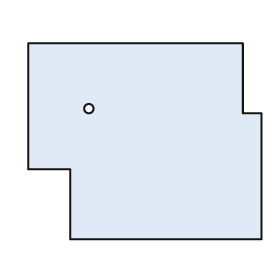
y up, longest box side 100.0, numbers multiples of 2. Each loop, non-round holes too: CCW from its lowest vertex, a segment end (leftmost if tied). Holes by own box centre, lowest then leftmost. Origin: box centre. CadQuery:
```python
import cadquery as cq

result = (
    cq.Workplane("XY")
    .moveTo(-32.0, -42.0)
    .lineTo(50.0, -42.0)
    .lineTo(50.0, 12.0)
    .lineTo(42.0, 12.0)
    .lineTo(42.0, 42.0)
    .lineTo(-50.0, 42.0)
    .lineTo(-50.0, -12.0)
    .lineTo(-32.0, -12.0)
    .close()
    .moveTo(-24.0, 14.0)
    .circle(2.0)
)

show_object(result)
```